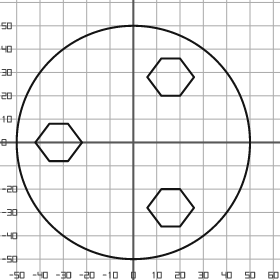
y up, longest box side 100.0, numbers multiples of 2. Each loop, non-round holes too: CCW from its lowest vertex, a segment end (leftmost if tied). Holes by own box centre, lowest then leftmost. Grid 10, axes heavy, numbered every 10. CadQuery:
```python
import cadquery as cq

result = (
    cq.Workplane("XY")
    .moveTo(0.0, 0.0)
    .circle(50.0)
    .moveTo(12.0, -36.0)
    .lineTo(20.0, -36.0)
    .lineTo(26.0, -28.0)
    .lineTo(20.0, -20.0)
    .lineTo(12.0, -20.0)
    .lineTo(6.0, -28.0)
    .close()
    .moveTo(-36.0, -8.0)
    .lineTo(-28.0, -8.0)
    .lineTo(-22.0, 0.0)
    .lineTo(-28.0, 8.0)
    .lineTo(-36.0, 8.0)
    .lineTo(-42.0, 0.0)
    .close()
    .moveTo(12.0, 20.0)
    .lineTo(20.0, 20.0)
    .lineTo(26.0, 28.0)
    .lineTo(20.0, 36.0)
    .lineTo(12.0, 36.0)
    .lineTo(6.0, 28.0)
    .close()
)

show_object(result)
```